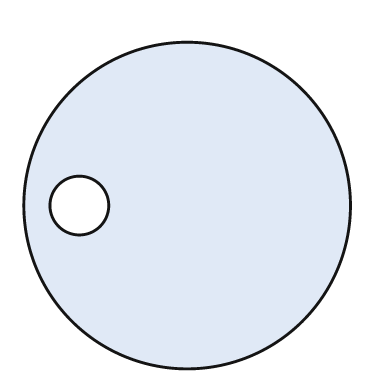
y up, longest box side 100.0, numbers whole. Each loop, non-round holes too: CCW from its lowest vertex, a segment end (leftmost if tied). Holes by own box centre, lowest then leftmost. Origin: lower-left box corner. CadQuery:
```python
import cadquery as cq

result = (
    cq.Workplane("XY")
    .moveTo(50.0, 50.0)
    .circle(50.0)
    .moveTo(17.0, 50.0)
    .circle(9.0)
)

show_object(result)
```